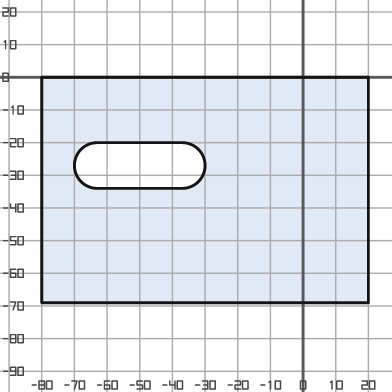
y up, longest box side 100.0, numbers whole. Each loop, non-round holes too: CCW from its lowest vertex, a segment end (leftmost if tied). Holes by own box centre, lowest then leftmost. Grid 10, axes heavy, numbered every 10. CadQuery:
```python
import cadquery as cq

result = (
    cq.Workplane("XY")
    .moveTo(-80.0, -69.0)
    .lineTo(20.0, -69.0)
    .lineTo(20.0, 0.0)
    .lineTo(-80.0, 0.0)
    .close()
    .moveTo(-63.0, -34.0)
    .lineTo(-37.0, -34.0)
    .threePointArc((-30.0, -27.0), (-37.0, -20.0))
    .lineTo(-63.0, -20.0)
    .threePointArc((-70.0, -27.0), (-63.0, -34.0))
    .close()
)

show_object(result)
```